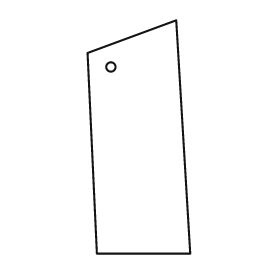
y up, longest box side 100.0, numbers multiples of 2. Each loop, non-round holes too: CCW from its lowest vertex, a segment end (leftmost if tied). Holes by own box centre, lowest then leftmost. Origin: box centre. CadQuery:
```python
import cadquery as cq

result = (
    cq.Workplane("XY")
    .moveTo(-18.0, -50.0)
    .lineTo(22.0, -50.0)
    .lineTo(16.0, 50.0)
    .lineTo(-22.0, 36.0)
    .close()
    .moveTo(-12.0, 30.0)
    .circle(2.0)
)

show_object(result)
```